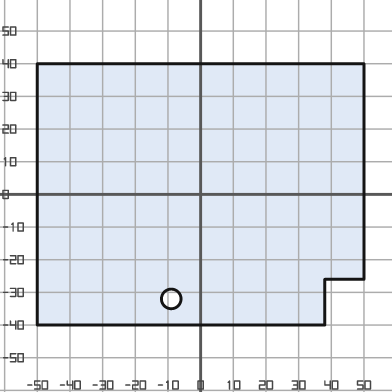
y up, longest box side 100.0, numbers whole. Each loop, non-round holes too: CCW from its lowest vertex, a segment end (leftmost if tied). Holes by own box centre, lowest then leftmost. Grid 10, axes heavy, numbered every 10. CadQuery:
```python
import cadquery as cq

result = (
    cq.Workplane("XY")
    .moveTo(-50.0, -40.0)
    .lineTo(38.0, -40.0)
    .lineTo(38.0, -26.0)
    .lineTo(50.0, -26.0)
    .lineTo(50.0, 40.0)
    .lineTo(-50.0, 40.0)
    .close()
    .moveTo(-9.0, -32.0)
    .circle(3.0)
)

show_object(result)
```